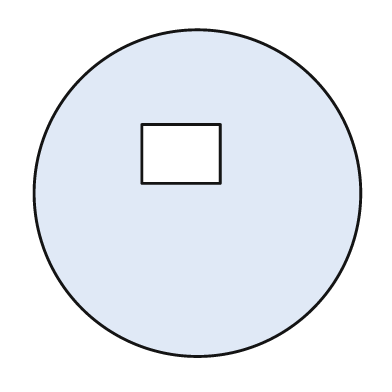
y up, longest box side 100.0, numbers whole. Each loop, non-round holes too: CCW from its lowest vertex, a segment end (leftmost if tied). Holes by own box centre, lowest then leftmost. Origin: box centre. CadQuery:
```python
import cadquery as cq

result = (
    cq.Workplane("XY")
    .moveTo(0.0, 0.0)
    .circle(50.0)
    .moveTo(-17.0, 3.0)
    .lineTo(7.0, 3.0)
    .lineTo(7.0, 21.0)
    .lineTo(-17.0, 21.0)
    .close()
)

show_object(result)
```